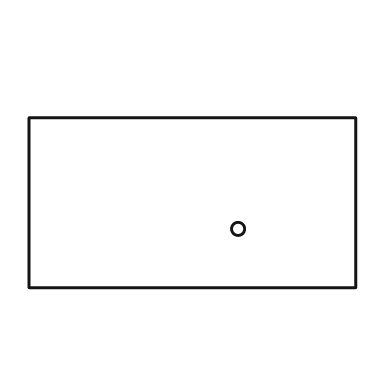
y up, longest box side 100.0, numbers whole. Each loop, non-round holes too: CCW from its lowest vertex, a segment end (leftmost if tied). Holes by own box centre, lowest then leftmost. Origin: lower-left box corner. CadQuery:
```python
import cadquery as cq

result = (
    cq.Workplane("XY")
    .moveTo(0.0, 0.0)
    .lineTo(100.0, 0.0)
    .lineTo(100.0, 52.0)
    .lineTo(0.0, 52.0)
    .close()
    .moveTo(64.0, 18.0)
    .circle(2.0)
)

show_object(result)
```